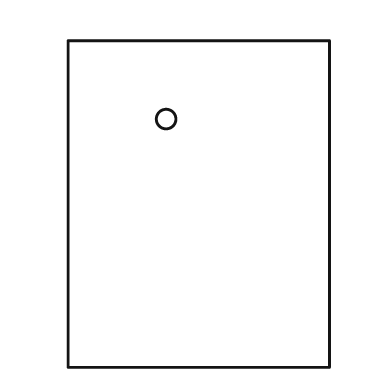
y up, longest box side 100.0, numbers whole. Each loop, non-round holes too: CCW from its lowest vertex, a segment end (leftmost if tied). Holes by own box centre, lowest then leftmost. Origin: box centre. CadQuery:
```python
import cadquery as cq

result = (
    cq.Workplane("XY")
    .moveTo(-40.0, -50.0)
    .lineTo(40.0, -50.0)
    .lineTo(40.0, 50.0)
    .lineTo(-40.0, 50.0)
    .close()
    .moveTo(-10.0, 26.0)
    .circle(3.0)
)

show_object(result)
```